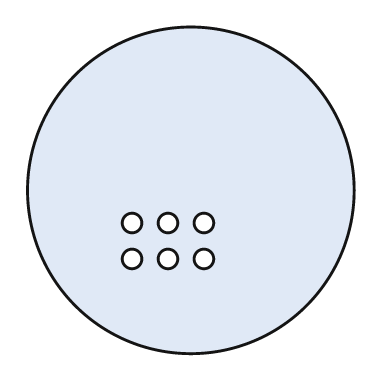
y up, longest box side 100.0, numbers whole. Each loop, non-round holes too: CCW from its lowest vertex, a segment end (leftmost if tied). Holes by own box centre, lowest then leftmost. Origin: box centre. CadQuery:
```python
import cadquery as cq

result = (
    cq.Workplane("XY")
    .moveTo(0.0, 0.0)
    .circle(50.0)
    .moveTo(-18.0, -21.0)
    .circle(3.0)
    .moveTo(-7.0, -21.0)
    .circle(3.0)
    .moveTo(4.0, -21.0)
    .circle(3.0)
    .moveTo(-18.0, -10.0)
    .circle(3.0)
    .moveTo(-7.0, -10.0)
    .circle(3.0)
    .moveTo(4.0, -10.0)
    .circle(3.0)
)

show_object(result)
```